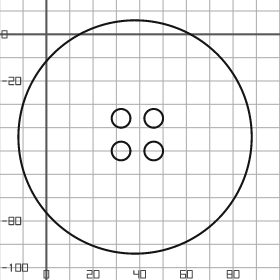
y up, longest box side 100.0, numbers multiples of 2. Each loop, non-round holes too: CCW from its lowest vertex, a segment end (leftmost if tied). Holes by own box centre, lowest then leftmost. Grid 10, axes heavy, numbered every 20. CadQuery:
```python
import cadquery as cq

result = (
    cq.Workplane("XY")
    .moveTo(38.0, -44.0)
    .circle(50.0)
    .moveTo(32.0, -50.0)
    .circle(4.0)
    .moveTo(46.0, -50.0)
    .circle(4.0)
    .moveTo(32.0, -36.0)
    .circle(4.0)
    .moveTo(46.0, -36.0)
    .circle(4.0)
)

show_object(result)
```